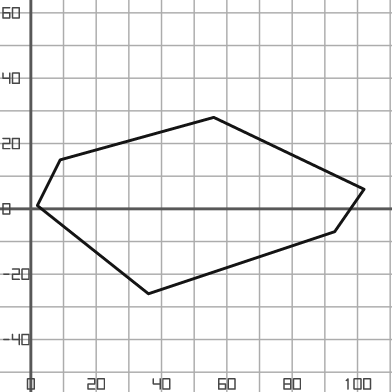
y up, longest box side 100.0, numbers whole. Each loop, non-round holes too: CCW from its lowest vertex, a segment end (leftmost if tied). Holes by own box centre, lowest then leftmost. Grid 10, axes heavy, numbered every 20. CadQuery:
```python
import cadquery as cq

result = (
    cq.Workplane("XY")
    .moveTo(36.0, -26.0)
    .lineTo(93.0, -7.0)
    .lineTo(102.0, 6.0)
    .lineTo(56.0, 28.0)
    .lineTo(9.0, 15.0)
    .lineTo(2.0, 1.0)
    .close()
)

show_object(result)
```